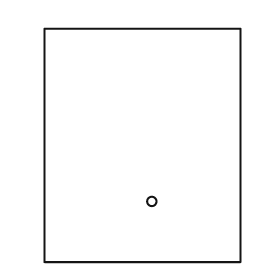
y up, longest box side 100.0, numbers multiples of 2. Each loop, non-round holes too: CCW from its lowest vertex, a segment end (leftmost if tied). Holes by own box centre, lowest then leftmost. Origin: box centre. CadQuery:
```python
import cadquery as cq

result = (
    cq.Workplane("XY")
    .moveTo(-42.0, -50.0)
    .lineTo(42.0, -50.0)
    .lineTo(42.0, 50.0)
    .lineTo(-42.0, 50.0)
    .close()
    .moveTo(4.0, -24.0)
    .circle(2.0)
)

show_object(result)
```